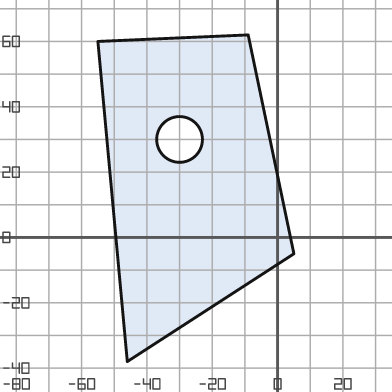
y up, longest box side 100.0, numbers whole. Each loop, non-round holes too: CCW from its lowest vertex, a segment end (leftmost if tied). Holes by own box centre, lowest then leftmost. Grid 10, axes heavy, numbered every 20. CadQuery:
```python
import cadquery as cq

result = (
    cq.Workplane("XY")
    .moveTo(-46.0, -38.0)
    .lineTo(5.0, -5.0)
    .lineTo(-9.0, 62.0)
    .lineTo(-55.0, 60.0)
    .close()
    .moveTo(-30.0, 30.0)
    .circle(7.0)
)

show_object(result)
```